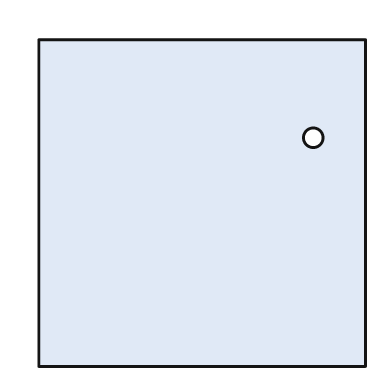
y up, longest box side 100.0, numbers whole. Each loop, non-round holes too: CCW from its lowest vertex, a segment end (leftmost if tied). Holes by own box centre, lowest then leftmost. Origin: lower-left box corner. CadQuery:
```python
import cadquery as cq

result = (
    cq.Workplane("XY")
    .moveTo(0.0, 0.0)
    .lineTo(100.0, 0.0)
    .lineTo(100.0, 100.0)
    .lineTo(0.0, 100.0)
    .close()
    .moveTo(84.0, 70.0)
    .circle(3.0)
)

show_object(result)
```